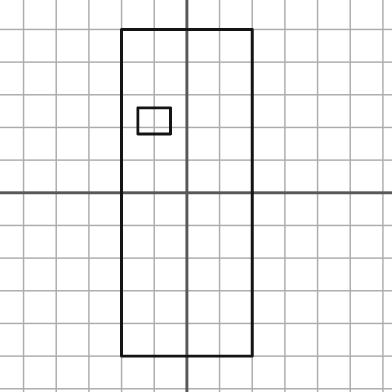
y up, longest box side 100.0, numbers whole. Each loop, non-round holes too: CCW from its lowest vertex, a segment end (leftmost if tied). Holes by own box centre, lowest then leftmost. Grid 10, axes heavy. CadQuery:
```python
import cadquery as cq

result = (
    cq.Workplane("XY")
    .moveTo(-20.0, -50.0)
    .lineTo(20.0, -50.0)
    .lineTo(20.0, 50.0)
    .lineTo(-20.0, 50.0)
    .close()
    .moveTo(-15.0, 18.0)
    .lineTo(-5.0, 18.0)
    .lineTo(-5.0, 26.0)
    .lineTo(-15.0, 26.0)
    .close()
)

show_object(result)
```